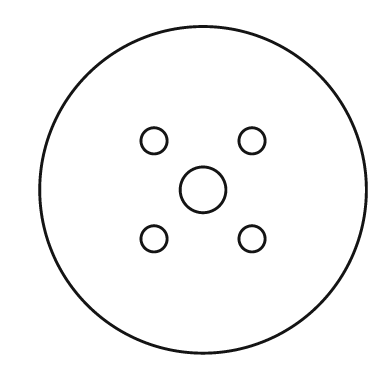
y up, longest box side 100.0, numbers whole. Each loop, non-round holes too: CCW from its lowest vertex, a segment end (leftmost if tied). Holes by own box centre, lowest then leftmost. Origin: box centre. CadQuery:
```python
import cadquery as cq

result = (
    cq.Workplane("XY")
    .moveTo(0.0, 0.0)
    .circle(50.0)
    .moveTo(-15.0, -15.0)
    .circle(4.0)
    .moveTo(15.0, -15.0)
    .circle(4.0)
    .moveTo(0.0, 0.0)
    .circle(7.0)
    .moveTo(-15.0, 15.0)
    .circle(4.0)
    .moveTo(15.0, 15.0)
    .circle(4.0)
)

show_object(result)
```